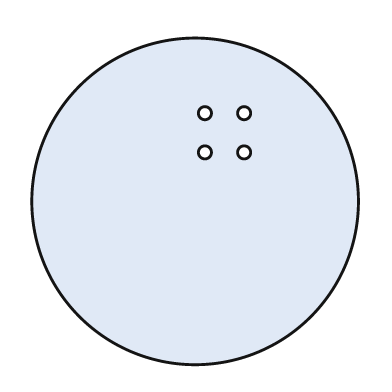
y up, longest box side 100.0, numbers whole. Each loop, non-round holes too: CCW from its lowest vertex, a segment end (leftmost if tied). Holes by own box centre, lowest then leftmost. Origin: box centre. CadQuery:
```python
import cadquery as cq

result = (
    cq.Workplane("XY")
    .moveTo(0.0, 0.0)
    .circle(50.0)
    .moveTo(3.0, 15.0)
    .circle(2.0)
    .moveTo(15.0, 15.0)
    .circle(2.0)
    .moveTo(3.0, 27.0)
    .circle(2.0)
    .moveTo(15.0, 27.0)
    .circle(2.0)
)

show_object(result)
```